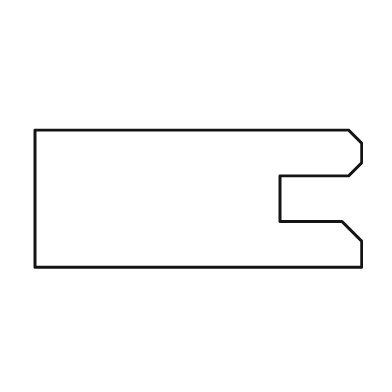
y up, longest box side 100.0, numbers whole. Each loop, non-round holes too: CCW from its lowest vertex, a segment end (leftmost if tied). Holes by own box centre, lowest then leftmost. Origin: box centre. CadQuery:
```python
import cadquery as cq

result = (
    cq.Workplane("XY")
    .moveTo(-50.0, -21.0)
    .lineTo(50.0, -21.0)
    .lineTo(50.0, -13.0)
    .lineTo(44.0, -7.0)
    .lineTo(25.0, -7.0)
    .lineTo(25.0, 7.0)
    .lineTo(46.0, 7.0)
    .lineTo(50.0, 11.0)
    .lineTo(50.0, 17.0)
    .lineTo(46.0, 21.0)
    .lineTo(-50.0, 21.0)
    .close()
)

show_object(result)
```